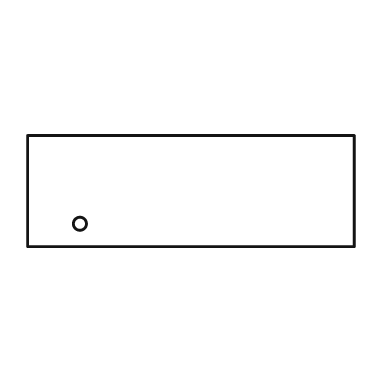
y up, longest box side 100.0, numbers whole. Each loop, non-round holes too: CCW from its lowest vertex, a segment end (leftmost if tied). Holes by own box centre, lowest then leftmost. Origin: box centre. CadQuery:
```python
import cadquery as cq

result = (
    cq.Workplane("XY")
    .moveTo(-50.0, -17.0)
    .lineTo(50.0, -17.0)
    .lineTo(50.0, 17.0)
    .lineTo(-50.0, 17.0)
    .close()
    .moveTo(-34.0, -10.0)
    .circle(2.0)
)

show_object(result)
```